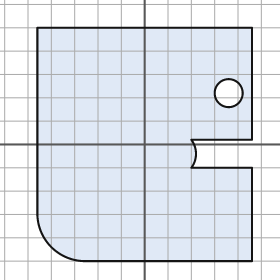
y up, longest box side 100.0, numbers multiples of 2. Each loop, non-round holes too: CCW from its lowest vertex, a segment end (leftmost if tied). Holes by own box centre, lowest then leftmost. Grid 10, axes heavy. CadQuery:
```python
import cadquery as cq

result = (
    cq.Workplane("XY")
    .moveTo(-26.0, -50.0)
    .lineTo(46.0, -50.0)
    .lineTo(46.0, -10.0)
    .lineTo(20.0, -10.0)
    .threePointArc((22.0, -4.0), (20.0, 2.0))
    .lineTo(46.0, 2.0)
    .lineTo(46.0, 50.0)
    .lineTo(-46.0, 50.0)
    .lineTo(-46.0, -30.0)
    .threePointArc((-40.0, -44.0), (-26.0, -50.0))
    .close()
    .moveTo(36.0, 22.0)
    .circle(6.0)
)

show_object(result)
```